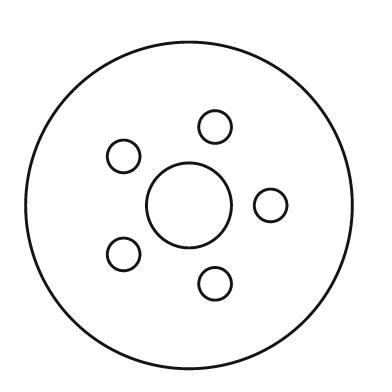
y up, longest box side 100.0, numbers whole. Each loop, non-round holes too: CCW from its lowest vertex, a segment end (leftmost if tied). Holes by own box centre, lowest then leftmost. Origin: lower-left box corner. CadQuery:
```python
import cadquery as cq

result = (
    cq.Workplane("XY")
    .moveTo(50.0, 50.0)
    .circle(50.0)
    .moveTo(58.0, 26.0)
    .circle(5.0)
    .moveTo(30.0, 35.0)
    .circle(5.0)
    .moveTo(50.0, 50.0)
    .circle(13.0)
    .moveTo(75.0, 50.0)
    .circle(5.0)
    .moveTo(30.0, 65.0)
    .circle(5.0)
    .moveTo(58.0, 74.0)
    .circle(5.0)
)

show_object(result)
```